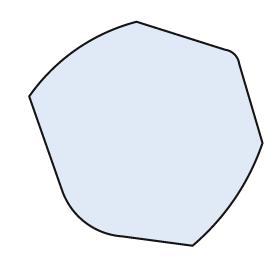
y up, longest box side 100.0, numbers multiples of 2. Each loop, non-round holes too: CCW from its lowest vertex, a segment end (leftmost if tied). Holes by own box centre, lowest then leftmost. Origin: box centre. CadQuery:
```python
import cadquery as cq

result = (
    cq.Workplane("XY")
    .moveTo(20.0, -48.0)
    .threePointArc((38.0, -28.0), (50.0, -4.0))
    .lineTo(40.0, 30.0)
    .threePointArc((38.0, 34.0), (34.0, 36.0))
    .lineTo(-4.0, 48.0)
    .threePointArc((-30.0, 36.0), (-50.0, 16.0))
    .lineTo(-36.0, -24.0)
    .threePointArc((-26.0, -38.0), (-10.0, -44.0))
    .close()
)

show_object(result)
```